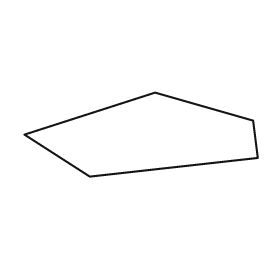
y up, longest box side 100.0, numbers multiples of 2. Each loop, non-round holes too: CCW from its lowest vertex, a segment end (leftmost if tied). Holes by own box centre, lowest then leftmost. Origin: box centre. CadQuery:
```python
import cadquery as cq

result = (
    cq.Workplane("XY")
    .moveTo(-22.0, -18.0)
    .lineTo(50.0, -10.0)
    .lineTo(48.0, 6.0)
    .lineTo(6.0, 18.0)
    .lineTo(-50.0, 0.0)
    .close()
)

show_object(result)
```